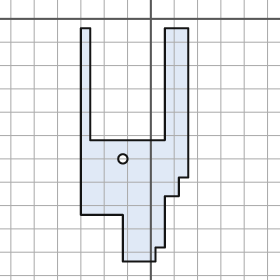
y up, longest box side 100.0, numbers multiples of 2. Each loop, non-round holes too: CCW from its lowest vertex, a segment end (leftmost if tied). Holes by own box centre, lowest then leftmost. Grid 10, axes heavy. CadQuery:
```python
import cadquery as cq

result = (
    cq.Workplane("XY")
    .moveTo(-12.0, -104.0)
    .lineTo(2.0, -104.0)
    .lineTo(2.0, -98.0)
    .lineTo(6.0, -98.0)
    .lineTo(6.0, -76.0)
    .lineTo(12.0, -76.0)
    .lineTo(12.0, -68.0)
    .lineTo(16.0, -68.0)
    .lineTo(16.0, -4.0)
    .lineTo(6.0, -4.0)
    .lineTo(6.0, -52.0)
    .lineTo(-26.0, -52.0)
    .lineTo(-26.0, -4.0)
    .lineTo(-30.0, -4.0)
    .lineTo(-30.0, -84.0)
    .lineTo(-12.0, -84.0)
    .close()
    .moveTo(-12.0, -60.0)
    .circle(2.0)
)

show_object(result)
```